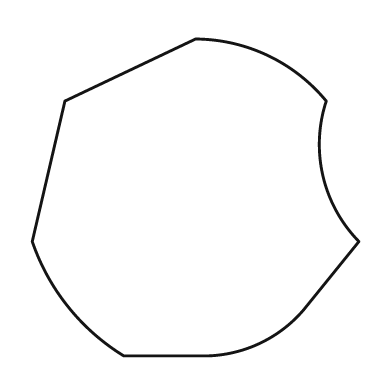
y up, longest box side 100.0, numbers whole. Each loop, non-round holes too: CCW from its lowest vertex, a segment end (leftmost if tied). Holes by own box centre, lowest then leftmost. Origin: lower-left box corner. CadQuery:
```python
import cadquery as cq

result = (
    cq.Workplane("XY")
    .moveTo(28.0, 0.0)
    .lineTo(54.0, 0.0)
    .threePointArc((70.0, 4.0), (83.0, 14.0))
    .lineTo(100.0, 35.0)
    .threePointArc((89.0, 55.0), (90.0, 78.0))
    .threePointArc((72.0, 92.0), (50.0, 97.0))
    .lineTo(10.0, 78.0)
    .lineTo(0.0, 35.0)
    .threePointArc((11.0, 15.0), (28.0, 0.0))
    .close()
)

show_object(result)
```